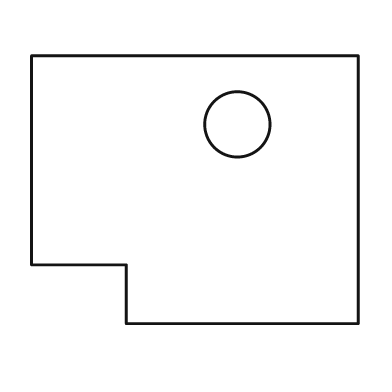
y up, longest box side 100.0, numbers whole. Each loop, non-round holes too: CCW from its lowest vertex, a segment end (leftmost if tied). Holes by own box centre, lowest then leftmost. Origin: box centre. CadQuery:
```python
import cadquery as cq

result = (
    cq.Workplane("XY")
    .moveTo(-21.0, -41.0)
    .lineTo(50.0, -41.0)
    .lineTo(50.0, 41.0)
    .lineTo(-50.0, 41.0)
    .lineTo(-50.0, -23.0)
    .lineTo(-21.0, -23.0)
    .close()
    .moveTo(13.0, 20.0)
    .circle(10.0)
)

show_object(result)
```